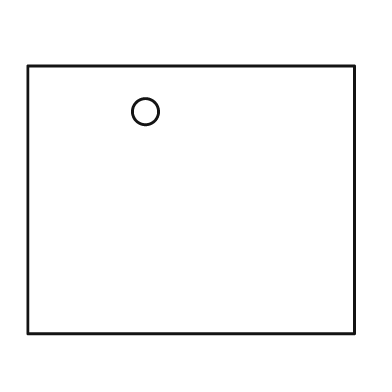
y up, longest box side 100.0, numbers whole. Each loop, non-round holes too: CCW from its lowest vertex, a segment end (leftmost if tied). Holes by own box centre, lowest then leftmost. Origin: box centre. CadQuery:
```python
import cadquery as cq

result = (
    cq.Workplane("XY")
    .moveTo(-50.0, -41.0)
    .lineTo(50.0, -41.0)
    .lineTo(50.0, 41.0)
    .lineTo(-50.0, 41.0)
    .close()
    .moveTo(-14.0, 27.0)
    .circle(4.0)
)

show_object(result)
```